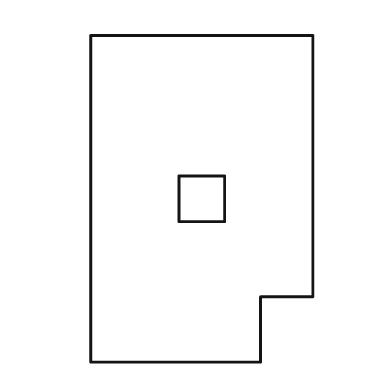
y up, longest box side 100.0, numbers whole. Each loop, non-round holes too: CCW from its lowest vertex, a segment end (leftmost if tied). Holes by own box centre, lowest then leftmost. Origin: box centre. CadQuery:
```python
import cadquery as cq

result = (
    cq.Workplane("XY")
    .moveTo(-34.0, -50.0)
    .lineTo(18.0, -50.0)
    .lineTo(18.0, -30.0)
    .lineTo(34.0, -30.0)
    .lineTo(34.0, 50.0)
    .lineTo(-34.0, 50.0)
    .close()
    .moveTo(-7.0, -7.0)
    .lineTo(7.0, -7.0)
    .lineTo(7.0, 7.0)
    .lineTo(-7.0, 7.0)
    .close()
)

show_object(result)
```